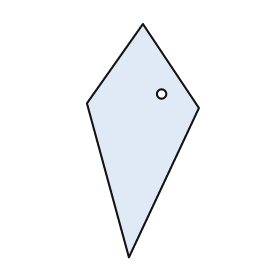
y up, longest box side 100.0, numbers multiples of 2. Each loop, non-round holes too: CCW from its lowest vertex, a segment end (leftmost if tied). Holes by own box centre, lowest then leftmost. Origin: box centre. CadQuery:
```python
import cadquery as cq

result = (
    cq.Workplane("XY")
    .moveTo(-6.0, -50.0)
    .lineTo(24.0, 14.0)
    .lineTo(0.0, 50.0)
    .lineTo(-24.0, 16.0)
    .close()
    .moveTo(8.0, 20.0)
    .circle(2.0)
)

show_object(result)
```